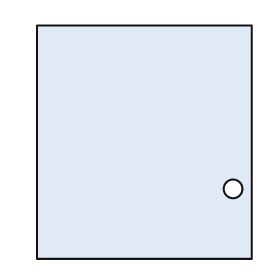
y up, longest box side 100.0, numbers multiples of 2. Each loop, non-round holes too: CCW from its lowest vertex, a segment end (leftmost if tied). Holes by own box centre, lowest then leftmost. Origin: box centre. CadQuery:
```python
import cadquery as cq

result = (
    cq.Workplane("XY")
    .moveTo(-46.0, -50.0)
    .lineTo(46.0, -50.0)
    .lineTo(46.0, 50.0)
    .lineTo(-46.0, 50.0)
    .close()
    .moveTo(38.0, -20.0)
    .circle(4.0)
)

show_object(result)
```